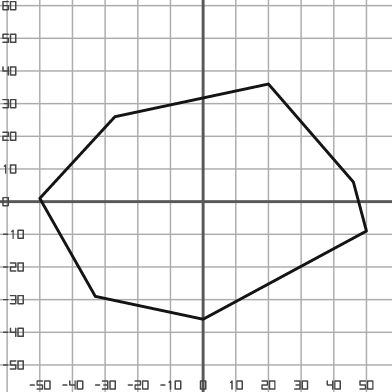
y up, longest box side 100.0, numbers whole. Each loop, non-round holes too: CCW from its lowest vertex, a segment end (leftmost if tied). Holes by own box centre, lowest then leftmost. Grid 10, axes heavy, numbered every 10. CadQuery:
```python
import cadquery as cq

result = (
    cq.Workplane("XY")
    .moveTo(0.0, -36.0)
    .lineTo(50.0, -9.0)
    .lineTo(46.0, 6.0)
    .lineTo(20.0, 36.0)
    .lineTo(-27.0, 26.0)
    .lineTo(-50.0, 1.0)
    .lineTo(-33.0, -29.0)
    .close()
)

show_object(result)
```